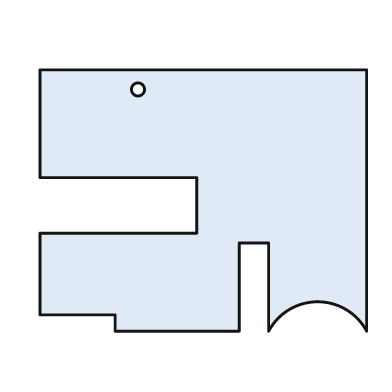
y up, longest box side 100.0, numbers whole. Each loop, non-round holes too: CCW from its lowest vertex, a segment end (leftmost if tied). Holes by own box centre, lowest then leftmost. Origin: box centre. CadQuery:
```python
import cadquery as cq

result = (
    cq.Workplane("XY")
    .moveTo(-27.0, -40.0)
    .lineTo(11.0, -40.0)
    .lineTo(11.0, -13.0)
    .lineTo(20.0, -13.0)
    .lineTo(20.0, -40.0)
    .threePointArc((35.0, -31.0), (50.0, -40.0))
    .lineTo(50.0, 40.0)
    .lineTo(-50.0, 40.0)
    .lineTo(-50.0, 7.0)
    .lineTo(-2.0, 7.0)
    .lineTo(-2.0, -10.0)
    .lineTo(-50.0, -10.0)
    .lineTo(-50.0, -35.0)
    .lineTo(-27.0, -35.0)
    .close()
    .moveTo(-20.0, 34.0)
    .circle(2.0)
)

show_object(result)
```